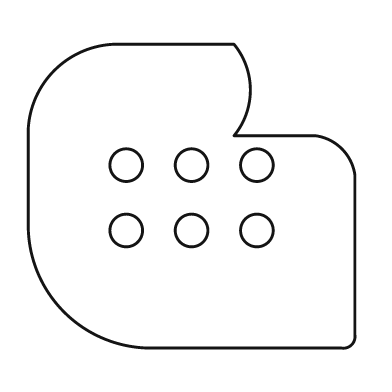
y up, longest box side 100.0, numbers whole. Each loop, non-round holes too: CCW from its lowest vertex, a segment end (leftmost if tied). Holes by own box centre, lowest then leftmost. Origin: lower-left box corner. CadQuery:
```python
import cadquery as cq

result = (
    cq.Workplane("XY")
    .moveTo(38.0, 0.0)
    .lineTo(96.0, 0.0)
    .threePointArc((99.0, 1.0), (100.0, 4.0))
    .lineTo(100.0, 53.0)
    .threePointArc((96.0, 61.0), (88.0, 65.0))
    .lineTo(63.0, 65.0)
    .threePointArc((68.0, 79.0), (63.0, 93.0))
    .lineTo(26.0, 93.0)
    .threePointArc((8.0, 85.0), (0.0, 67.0))
    .lineTo(0.0, 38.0)
    .threePointArc((11.0, 11.0), (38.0, 0.0))
    .close()
    .moveTo(30.0, 36.0)
    .circle(5.0)
    .moveTo(50.0, 36.0)
    .circle(5.0)
    .moveTo(70.0, 36.0)
    .circle(5.0)
    .moveTo(30.0, 56.0)
    .circle(5.0)
    .moveTo(50.0, 56.0)
    .circle(5.0)
    .moveTo(70.0, 56.0)
    .circle(5.0)
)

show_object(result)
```